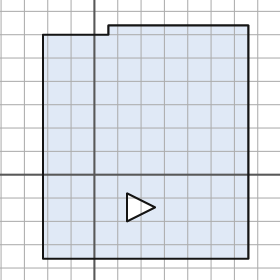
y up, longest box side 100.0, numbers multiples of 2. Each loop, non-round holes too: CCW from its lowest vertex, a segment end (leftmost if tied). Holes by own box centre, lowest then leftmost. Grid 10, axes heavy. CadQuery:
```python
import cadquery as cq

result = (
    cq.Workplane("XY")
    .moveTo(-22.0, -36.0)
    .lineTo(66.0, -36.0)
    .lineTo(66.0, 64.0)
    .lineTo(6.0, 64.0)
    .lineTo(6.0, 60.0)
    .lineTo(-22.0, 60.0)
    .close()
    .moveTo(14.0, -20.0)
    .lineTo(26.0, -14.0)
    .lineTo(14.0, -8.0)
    .close()
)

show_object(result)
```